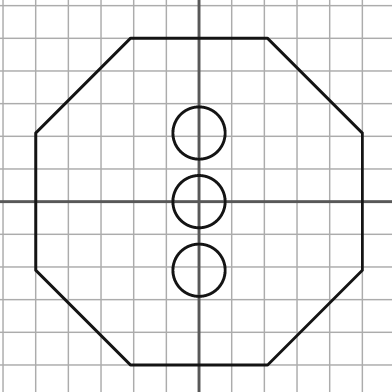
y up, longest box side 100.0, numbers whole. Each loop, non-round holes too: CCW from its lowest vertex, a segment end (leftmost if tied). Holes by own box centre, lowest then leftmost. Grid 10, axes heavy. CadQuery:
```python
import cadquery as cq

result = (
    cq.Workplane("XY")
    .moveTo(-21.0, -50.0)
    .lineTo(21.0, -50.0)
    .lineTo(50.0, -21.0)
    .lineTo(50.0, 21.0)
    .lineTo(21.0, 50.0)
    .lineTo(-21.0, 50.0)
    .lineTo(-50.0, 21.0)
    .lineTo(-50.0, -21.0)
    .close()
    .moveTo(0.0, -21.0)
    .circle(8.0)
    .moveTo(0.0, 0.0)
    .circle(8.0)
    .moveTo(0.0, 21.0)
    .circle(8.0)
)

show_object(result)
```